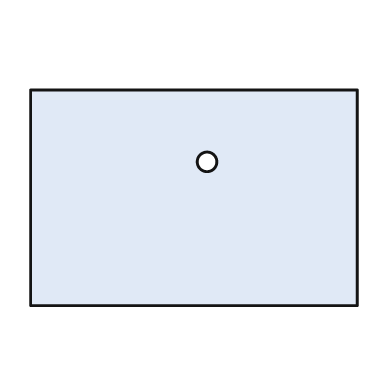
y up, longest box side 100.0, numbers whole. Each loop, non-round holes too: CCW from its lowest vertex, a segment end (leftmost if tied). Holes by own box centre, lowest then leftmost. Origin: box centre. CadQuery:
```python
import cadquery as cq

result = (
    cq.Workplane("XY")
    .moveTo(-50.0, -33.0)
    .lineTo(50.0, -33.0)
    .lineTo(50.0, 33.0)
    .lineTo(-50.0, 33.0)
    .close()
    .moveTo(4.0, 11.0)
    .circle(3.0)
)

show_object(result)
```